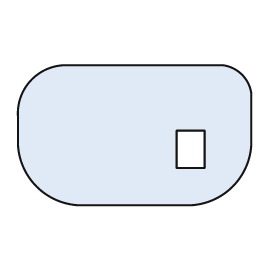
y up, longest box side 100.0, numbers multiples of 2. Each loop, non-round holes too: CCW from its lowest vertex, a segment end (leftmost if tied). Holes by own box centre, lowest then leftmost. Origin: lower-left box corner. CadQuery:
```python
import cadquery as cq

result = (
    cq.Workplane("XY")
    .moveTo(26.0, 0.0)
    .lineTo(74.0, 0.0)
    .threePointArc((92.0, 8.0), (100.0, 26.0))
    .lineTo(100.0, 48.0)
    .threePointArc((96.0, 56.0), (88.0, 60.0))
    .lineTo(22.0, 60.0)
    .threePointArc((6.0, 54.0), (0.0, 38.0))
    .lineTo(0.0, 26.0)
    .threePointArc((8.0, 8.0), (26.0, 0.0))
    .close()
    .moveTo(68.0, 16.0)
    .lineTo(80.0, 16.0)
    .lineTo(80.0, 32.0)
    .lineTo(68.0, 32.0)
    .close()
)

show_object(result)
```